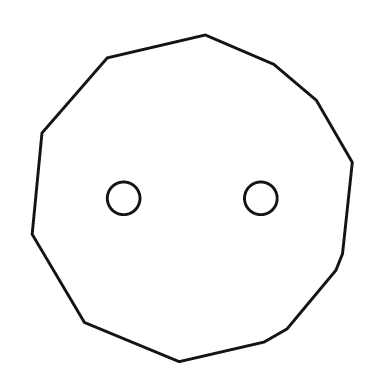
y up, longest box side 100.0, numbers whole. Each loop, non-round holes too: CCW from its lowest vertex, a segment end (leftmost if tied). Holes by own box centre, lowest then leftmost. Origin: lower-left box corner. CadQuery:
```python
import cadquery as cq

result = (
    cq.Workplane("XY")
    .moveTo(45.0, 0.0)
    .lineTo(71.0, 6.0)
    .lineTo(78.0, 10.0)
    .lineTo(93.0, 28.0)
    .lineTo(95.0, 33.0)
    .lineTo(98.0, 61.0)
    .lineTo(87.0, 80.0)
    .lineTo(74.0, 91.0)
    .lineTo(53.0, 100.0)
    .lineTo(23.0, 93.0)
    .lineTo(3.0, 70.0)
    .lineTo(0.0, 39.0)
    .lineTo(16.0, 12.0)
    .close()
    .moveTo(28.0, 50.0)
    .circle(5.0)
    .moveTo(70.0, 50.0)
    .circle(5.0)
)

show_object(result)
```